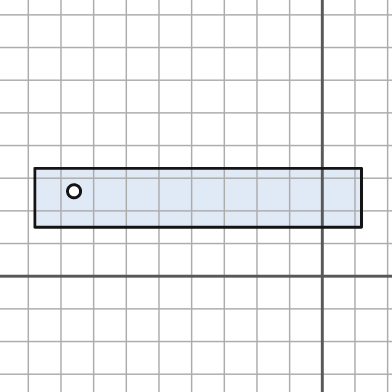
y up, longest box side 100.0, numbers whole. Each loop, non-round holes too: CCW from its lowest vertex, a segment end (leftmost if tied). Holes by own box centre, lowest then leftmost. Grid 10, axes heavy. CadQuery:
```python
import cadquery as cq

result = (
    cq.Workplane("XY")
    .moveTo(-88.0, 15.0)
    .lineTo(12.0, 15.0)
    .lineTo(12.0, 33.0)
    .lineTo(-88.0, 33.0)
    .close()
    .moveTo(-76.0, 26.0)
    .circle(2.0)
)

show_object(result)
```